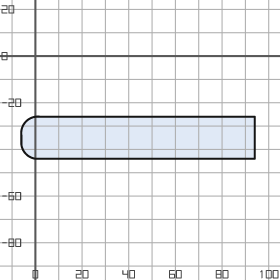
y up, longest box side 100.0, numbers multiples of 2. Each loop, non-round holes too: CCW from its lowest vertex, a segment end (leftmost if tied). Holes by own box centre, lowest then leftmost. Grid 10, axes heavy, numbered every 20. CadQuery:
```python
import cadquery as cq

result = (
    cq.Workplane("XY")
    .moveTo(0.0, -44.0)
    .lineTo(94.0, -44.0)
    .lineTo(94.0, -26.0)
    .lineTo(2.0, -26.0)
    .threePointArc((-4.0, -28.0), (-6.0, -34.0))
    .lineTo(-6.0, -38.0)
    .threePointArc((-4.0, -42.0), (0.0, -44.0))
    .close()
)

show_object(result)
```